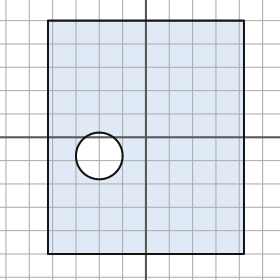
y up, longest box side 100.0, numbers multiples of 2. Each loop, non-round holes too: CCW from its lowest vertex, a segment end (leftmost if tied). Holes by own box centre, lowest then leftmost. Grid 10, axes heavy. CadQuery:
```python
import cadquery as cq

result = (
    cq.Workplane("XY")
    .moveTo(-42.0, -50.0)
    .lineTo(42.0, -50.0)
    .lineTo(42.0, 50.0)
    .lineTo(-42.0, 50.0)
    .close()
    .moveTo(-20.0, -8.0)
    .circle(10.0)
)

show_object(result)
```